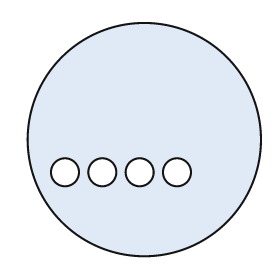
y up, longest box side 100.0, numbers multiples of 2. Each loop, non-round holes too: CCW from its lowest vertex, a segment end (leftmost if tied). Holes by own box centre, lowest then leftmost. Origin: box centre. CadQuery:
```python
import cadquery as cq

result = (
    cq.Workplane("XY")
    .moveTo(0.0, 0.0)
    .circle(50.0)
    .moveTo(-34.0, -14.0)
    .circle(6.0)
    .moveTo(-18.0, -14.0)
    .circle(6.0)
    .moveTo(-2.0, -14.0)
    .circle(6.0)
    .moveTo(14.0, -14.0)
    .circle(6.0)
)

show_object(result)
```